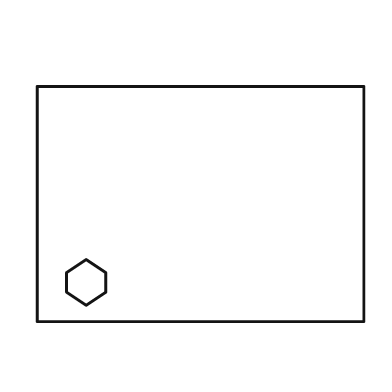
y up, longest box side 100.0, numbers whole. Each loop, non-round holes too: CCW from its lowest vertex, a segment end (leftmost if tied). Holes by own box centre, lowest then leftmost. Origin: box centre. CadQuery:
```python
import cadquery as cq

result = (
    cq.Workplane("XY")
    .moveTo(-50.0, -36.0)
    .lineTo(50.0, -36.0)
    .lineTo(50.0, 36.0)
    .lineTo(-50.0, 36.0)
    .close()
    .moveTo(-35.0, -31.0)
    .lineTo(-29.0, -27.0)
    .lineTo(-29.0, -21.0)
    .lineTo(-35.0, -17.0)
    .lineTo(-41.0, -21.0)
    .lineTo(-41.0, -27.0)
    .close()
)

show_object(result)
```